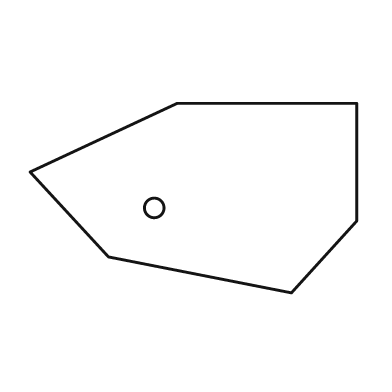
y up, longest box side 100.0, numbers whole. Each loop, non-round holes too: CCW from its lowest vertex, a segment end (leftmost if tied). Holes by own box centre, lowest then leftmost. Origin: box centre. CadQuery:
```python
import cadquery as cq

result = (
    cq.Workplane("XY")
    .moveTo(30.0, -29.0)
    .lineTo(50.0, -7.0)
    .lineTo(50.0, 29.0)
    .lineTo(-5.0, 29.0)
    .lineTo(-50.0, 8.0)
    .lineTo(-26.0, -18.0)
    .close()
    .moveTo(-12.0, -3.0)
    .circle(3.0)
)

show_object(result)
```